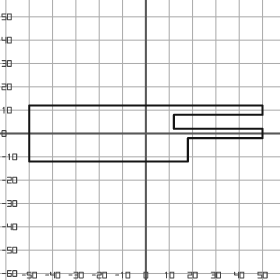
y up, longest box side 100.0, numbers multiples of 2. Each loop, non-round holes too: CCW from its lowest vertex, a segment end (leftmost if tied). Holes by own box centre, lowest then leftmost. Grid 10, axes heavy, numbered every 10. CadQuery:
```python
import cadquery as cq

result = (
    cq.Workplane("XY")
    .moveTo(-50.0, -12.0)
    .lineTo(18.0, -12.0)
    .lineTo(18.0, -2.0)
    .lineTo(50.0, -2.0)
    .lineTo(50.0, 2.0)
    .lineTo(12.0, 2.0)
    .lineTo(12.0, 8.0)
    .lineTo(50.0, 8.0)
    .lineTo(50.0, 12.0)
    .lineTo(-50.0, 12.0)
    .close()
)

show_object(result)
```